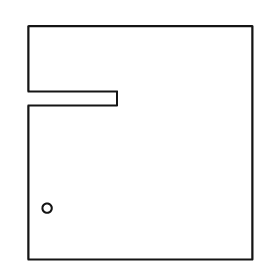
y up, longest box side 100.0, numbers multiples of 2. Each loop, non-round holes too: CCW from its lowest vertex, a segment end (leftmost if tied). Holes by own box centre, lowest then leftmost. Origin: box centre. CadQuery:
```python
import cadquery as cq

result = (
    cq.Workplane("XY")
    .moveTo(-48.0, -50.0)
    .lineTo(48.0, -50.0)
    .lineTo(48.0, 50.0)
    .lineTo(-48.0, 50.0)
    .lineTo(-48.0, 22.0)
    .lineTo(-10.0, 22.0)
    .lineTo(-10.0, 16.0)
    .lineTo(-48.0, 16.0)
    .close()
    .moveTo(-40.0, -28.0)
    .circle(2.0)
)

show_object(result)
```